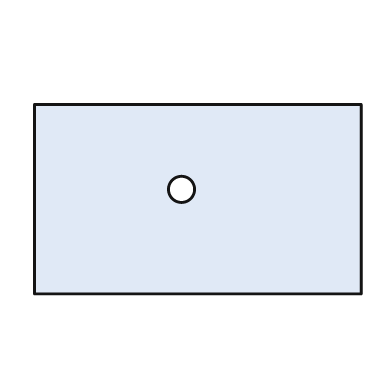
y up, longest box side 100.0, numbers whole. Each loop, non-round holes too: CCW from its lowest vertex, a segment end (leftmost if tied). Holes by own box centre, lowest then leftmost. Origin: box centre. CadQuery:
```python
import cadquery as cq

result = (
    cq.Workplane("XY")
    .moveTo(-50.0, -29.0)
    .lineTo(50.0, -29.0)
    .lineTo(50.0, 29.0)
    .lineTo(-50.0, 29.0)
    .close()
    .moveTo(-5.0, 3.0)
    .circle(4.0)
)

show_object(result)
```